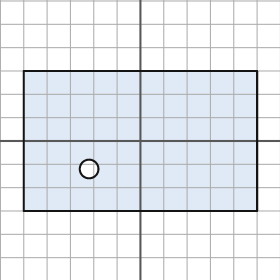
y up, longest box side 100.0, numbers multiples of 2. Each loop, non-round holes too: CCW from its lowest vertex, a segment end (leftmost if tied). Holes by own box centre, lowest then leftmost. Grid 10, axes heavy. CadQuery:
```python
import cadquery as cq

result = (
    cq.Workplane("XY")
    .moveTo(-50.0, -30.0)
    .lineTo(50.0, -30.0)
    .lineTo(50.0, 30.0)
    .lineTo(-50.0, 30.0)
    .close()
    .moveTo(-22.0, -12.0)
    .circle(4.0)
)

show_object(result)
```